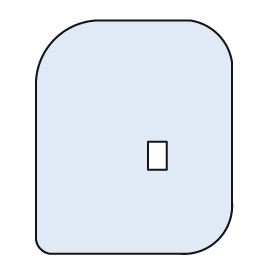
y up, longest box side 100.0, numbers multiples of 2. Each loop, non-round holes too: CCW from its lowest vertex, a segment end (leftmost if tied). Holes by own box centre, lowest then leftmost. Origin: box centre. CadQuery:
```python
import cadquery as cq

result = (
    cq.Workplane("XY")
    .moveTo(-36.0, -50.0)
    .lineTo(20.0, -50.0)
    .threePointArc((36.0, -44.0), (42.0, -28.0))
    .lineTo(42.0, 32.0)
    .threePointArc((36.0, 44.0), (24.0, 50.0))
    .lineTo(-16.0, 50.0)
    .threePointArc((-34.0, 42.0), (-42.0, 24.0))
    .lineTo(-42.0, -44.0)
    .threePointArc((-40.0, -48.0), (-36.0, -50.0))
    .close()
    .moveTo(6.0, -14.0)
    .lineTo(14.0, -14.0)
    .lineTo(14.0, -2.0)
    .lineTo(6.0, -2.0)
    .close()
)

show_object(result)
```